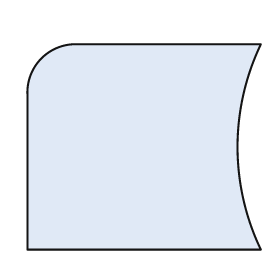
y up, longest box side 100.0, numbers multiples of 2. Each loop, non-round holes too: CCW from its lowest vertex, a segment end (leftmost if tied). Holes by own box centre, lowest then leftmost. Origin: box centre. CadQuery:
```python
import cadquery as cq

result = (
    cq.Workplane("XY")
    .moveTo(-50.0, -44.0)
    .lineTo(50.0, -44.0)
    .threePointArc((40.0, 0.0), (50.0, 44.0))
    .lineTo(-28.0, 44.0)
    .threePointArc((-44.0, 38.0), (-50.0, 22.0))
    .close()
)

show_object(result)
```